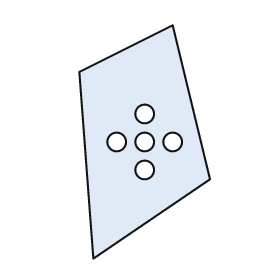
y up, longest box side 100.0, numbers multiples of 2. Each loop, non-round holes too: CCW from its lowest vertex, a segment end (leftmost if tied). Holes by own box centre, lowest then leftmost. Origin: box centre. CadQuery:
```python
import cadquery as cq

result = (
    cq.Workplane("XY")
    .moveTo(-22.0, -50.0)
    .lineTo(28.0, -16.0)
    .lineTo(12.0, 50.0)
    .lineTo(-28.0, 30.0)
    .close()
    .moveTo(0.0, -12.0)
    .circle(4.0)
    .moveTo(-12.0, 0.0)
    .circle(4.0)
    .moveTo(0.0, 0.0)
    .circle(4.0)
    .moveTo(12.0, 0.0)
    .circle(4.0)
    .moveTo(0.0, 12.0)
    .circle(4.0)
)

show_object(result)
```